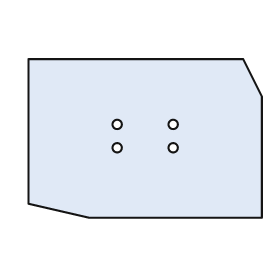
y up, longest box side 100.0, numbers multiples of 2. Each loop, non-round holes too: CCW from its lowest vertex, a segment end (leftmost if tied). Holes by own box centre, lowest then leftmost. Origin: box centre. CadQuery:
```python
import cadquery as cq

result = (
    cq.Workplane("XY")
    .moveTo(-24.0, -34.0)
    .lineTo(50.0, -34.0)
    .lineTo(50.0, 18.0)
    .lineTo(42.0, 34.0)
    .lineTo(-50.0, 34.0)
    .lineTo(-50.0, -28.0)
    .close()
    .moveTo(-12.0, -4.0)
    .circle(2.0)
    .moveTo(12.0, -4.0)
    .circle(2.0)
    .moveTo(-12.0, 6.0)
    .circle(2.0)
    .moveTo(12.0, 6.0)
    .circle(2.0)
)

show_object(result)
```